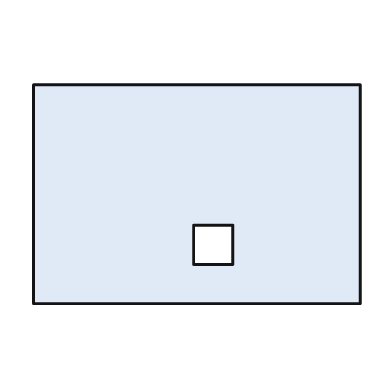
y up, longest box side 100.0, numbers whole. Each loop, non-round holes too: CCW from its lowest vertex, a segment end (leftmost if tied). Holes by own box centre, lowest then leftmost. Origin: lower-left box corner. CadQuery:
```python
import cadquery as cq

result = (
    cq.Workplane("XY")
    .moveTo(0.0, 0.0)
    .lineTo(100.0, 0.0)
    .lineTo(100.0, 67.0)
    .lineTo(0.0, 67.0)
    .close()
    .moveTo(49.0, 12.0)
    .lineTo(61.0, 12.0)
    .lineTo(61.0, 24.0)
    .lineTo(49.0, 24.0)
    .close()
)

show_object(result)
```